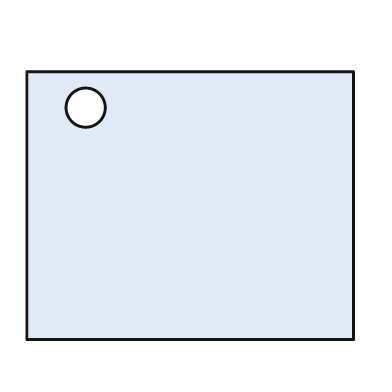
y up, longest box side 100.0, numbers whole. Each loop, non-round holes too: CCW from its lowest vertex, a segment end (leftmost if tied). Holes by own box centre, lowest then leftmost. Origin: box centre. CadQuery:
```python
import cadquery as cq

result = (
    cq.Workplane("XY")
    .moveTo(-50.0, -41.0)
    .lineTo(50.0, -41.0)
    .lineTo(50.0, 41.0)
    .lineTo(-50.0, 41.0)
    .close()
    .moveTo(-32.0, 30.0)
    .circle(6.0)
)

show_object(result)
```